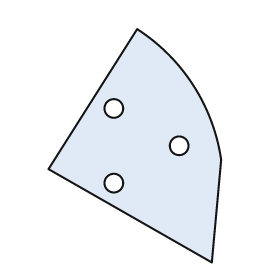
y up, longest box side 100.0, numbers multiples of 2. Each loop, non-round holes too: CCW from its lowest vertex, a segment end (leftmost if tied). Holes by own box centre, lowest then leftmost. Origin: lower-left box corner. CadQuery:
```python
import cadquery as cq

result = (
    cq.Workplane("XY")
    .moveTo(70.0, 0.0)
    .lineTo(74.0, 44.0)
    .threePointArc((62.0, 76.0), (38.0, 100.0))
    .lineTo(0.0, 40.0)
    .close()
    .moveTo(28.0, 34.0)
    .circle(4.0)
    .moveTo(56.0, 50.0)
    .circle(4.0)
    .moveTo(28.0, 66.0)
    .circle(4.0)
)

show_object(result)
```